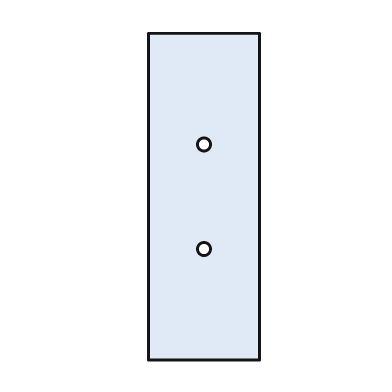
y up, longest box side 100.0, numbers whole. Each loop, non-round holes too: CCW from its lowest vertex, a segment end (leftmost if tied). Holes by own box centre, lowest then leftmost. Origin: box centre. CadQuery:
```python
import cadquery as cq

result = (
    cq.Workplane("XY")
    .moveTo(-17.0, -50.0)
    .lineTo(17.0, -50.0)
    .lineTo(17.0, 50.0)
    .lineTo(-17.0, 50.0)
    .close()
    .moveTo(0.0, -16.0)
    .circle(2.0)
    .moveTo(0.0, 16.0)
    .circle(2.0)
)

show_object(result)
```